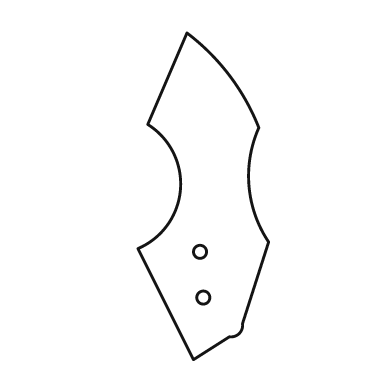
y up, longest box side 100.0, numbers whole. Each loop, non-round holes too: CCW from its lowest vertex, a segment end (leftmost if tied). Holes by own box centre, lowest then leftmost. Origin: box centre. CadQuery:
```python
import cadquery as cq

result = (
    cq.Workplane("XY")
    .moveTo(-3.0, -50.0)
    .lineTo(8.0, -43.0)
    .threePointArc((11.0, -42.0), (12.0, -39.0))
    .lineTo(20.0, -14.0)
    .threePointArc((14.0, 3.0), (17.0, 21.0))
    .threePointArc((8.0, 37.0), (-5.0, 50.0))
    .lineTo(-17.0, 22.0)
    .threePointArc((-7.0, 2.0), (-20.0, -16.0))
    .close()
    .moveTo(0.0, -31.0)
    .circle(2.0)
    .moveTo(-1.0, -17.0)
    .circle(2.0)
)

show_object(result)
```